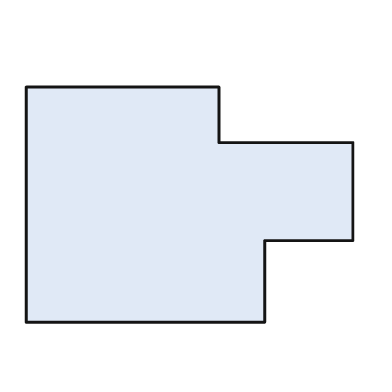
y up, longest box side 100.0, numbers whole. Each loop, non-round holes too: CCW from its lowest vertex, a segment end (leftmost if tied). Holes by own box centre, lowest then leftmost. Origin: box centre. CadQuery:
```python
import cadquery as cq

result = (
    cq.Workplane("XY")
    .moveTo(-50.0, -36.0)
    .lineTo(23.0, -36.0)
    .lineTo(23.0, -11.0)
    .lineTo(50.0, -11.0)
    .lineTo(50.0, 19.0)
    .lineTo(9.0, 19.0)
    .lineTo(9.0, 36.0)
    .lineTo(-50.0, 36.0)
    .close()
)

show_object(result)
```